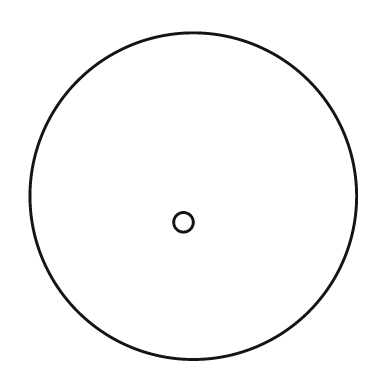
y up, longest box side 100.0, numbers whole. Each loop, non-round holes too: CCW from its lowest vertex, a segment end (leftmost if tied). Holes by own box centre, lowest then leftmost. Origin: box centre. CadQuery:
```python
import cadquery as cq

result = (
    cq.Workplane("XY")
    .moveTo(0.0, 0.0)
    .circle(50.0)
    .moveTo(-3.0, -8.0)
    .circle(3.0)
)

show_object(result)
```